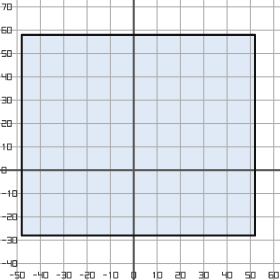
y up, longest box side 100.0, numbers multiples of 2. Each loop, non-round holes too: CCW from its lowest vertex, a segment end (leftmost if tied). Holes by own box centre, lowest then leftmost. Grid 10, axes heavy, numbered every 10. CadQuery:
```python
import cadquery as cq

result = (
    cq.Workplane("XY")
    .moveTo(-48.0, -28.0)
    .lineTo(52.0, -28.0)
    .lineTo(52.0, 58.0)
    .lineTo(-48.0, 58.0)
    .close()
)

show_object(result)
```